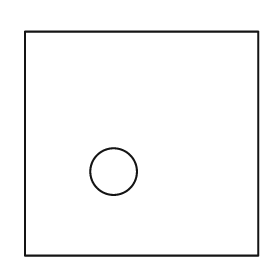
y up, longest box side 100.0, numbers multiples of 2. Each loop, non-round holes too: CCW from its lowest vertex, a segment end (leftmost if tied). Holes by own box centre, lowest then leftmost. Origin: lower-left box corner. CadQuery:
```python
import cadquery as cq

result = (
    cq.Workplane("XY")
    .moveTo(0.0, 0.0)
    .lineTo(100.0, 0.0)
    .lineTo(100.0, 96.0)
    .lineTo(0.0, 96.0)
    .close()
    .moveTo(38.0, 36.0)
    .circle(10.0)
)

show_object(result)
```